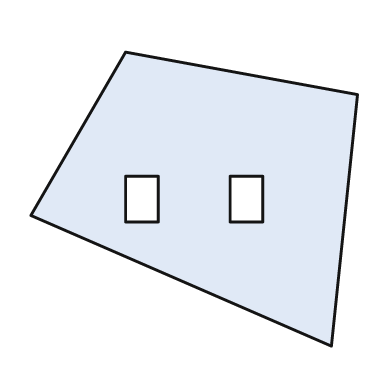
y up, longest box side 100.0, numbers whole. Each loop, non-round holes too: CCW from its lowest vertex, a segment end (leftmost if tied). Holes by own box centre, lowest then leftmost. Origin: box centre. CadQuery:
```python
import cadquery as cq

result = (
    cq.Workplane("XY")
    .moveTo(42.0, -45.0)
    .lineTo(50.0, 32.0)
    .lineTo(-21.0, 45.0)
    .lineTo(-50.0, -5.0)
    .close()
    .moveTo(-21.0, -7.0)
    .lineTo(-11.0, -7.0)
    .lineTo(-11.0, 7.0)
    .lineTo(-21.0, 7.0)
    .close()
    .moveTo(11.0, -7.0)
    .lineTo(21.0, -7.0)
    .lineTo(21.0, 7.0)
    .lineTo(11.0, 7.0)
    .close()
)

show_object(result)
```